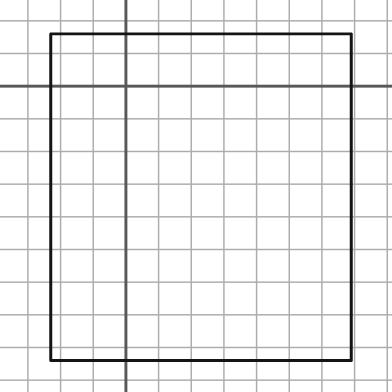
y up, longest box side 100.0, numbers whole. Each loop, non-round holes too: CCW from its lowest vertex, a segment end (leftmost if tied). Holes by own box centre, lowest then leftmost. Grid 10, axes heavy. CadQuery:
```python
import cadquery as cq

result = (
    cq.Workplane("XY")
    .moveTo(-23.0, -84.0)
    .lineTo(69.0, -84.0)
    .lineTo(69.0, 16.0)
    .lineTo(-23.0, 16.0)
    .close()
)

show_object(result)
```